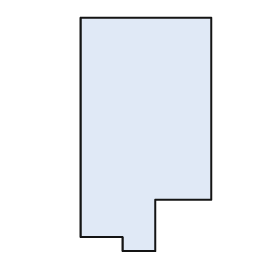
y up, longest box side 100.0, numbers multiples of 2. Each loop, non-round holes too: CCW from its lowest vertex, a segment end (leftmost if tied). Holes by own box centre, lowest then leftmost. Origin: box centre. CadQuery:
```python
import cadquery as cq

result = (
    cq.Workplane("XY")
    .moveTo(-10.0, -50.0)
    .lineTo(4.0, -50.0)
    .lineTo(4.0, -28.0)
    .lineTo(28.0, -28.0)
    .lineTo(28.0, 50.0)
    .lineTo(-28.0, 50.0)
    .lineTo(-28.0, -44.0)
    .lineTo(-10.0, -44.0)
    .close()
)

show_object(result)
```